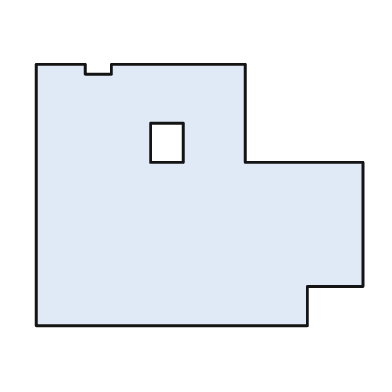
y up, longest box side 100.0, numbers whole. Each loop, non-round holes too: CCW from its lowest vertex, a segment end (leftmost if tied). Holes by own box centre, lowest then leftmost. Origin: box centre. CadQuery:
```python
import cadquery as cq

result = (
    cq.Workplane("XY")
    .moveTo(-50.0, -40.0)
    .lineTo(33.0, -40.0)
    .lineTo(33.0, -28.0)
    .lineTo(50.0, -28.0)
    .lineTo(50.0, 10.0)
    .lineTo(14.0, 10.0)
    .lineTo(14.0, 40.0)
    .lineTo(-27.0, 40.0)
    .lineTo(-27.0, 37.0)
    .lineTo(-35.0, 37.0)
    .lineTo(-35.0, 40.0)
    .lineTo(-50.0, 40.0)
    .close()
    .moveTo(-15.0, 10.0)
    .lineTo(-5.0, 10.0)
    .lineTo(-5.0, 22.0)
    .lineTo(-15.0, 22.0)
    .close()
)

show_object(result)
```